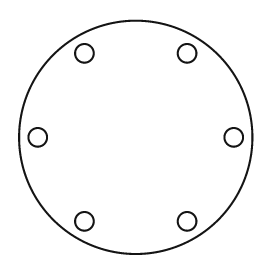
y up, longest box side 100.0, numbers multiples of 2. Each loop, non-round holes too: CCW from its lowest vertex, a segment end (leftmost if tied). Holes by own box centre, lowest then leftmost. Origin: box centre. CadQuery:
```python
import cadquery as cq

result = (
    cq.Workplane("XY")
    .moveTo(0.0, 0.0)
    .circle(50.0)
    .moveTo(-22.0, -36.0)
    .circle(4.0)
    .moveTo(22.0, -36.0)
    .circle(4.0)
    .moveTo(-42.0, 0.0)
    .circle(4.0)
    .moveTo(42.0, 0.0)
    .circle(4.0)
    .moveTo(-22.0, 36.0)
    .circle(4.0)
    .moveTo(22.0, 36.0)
    .circle(4.0)
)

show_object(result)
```